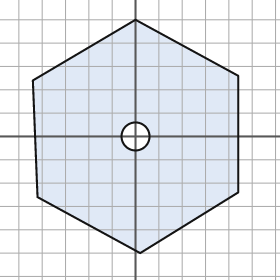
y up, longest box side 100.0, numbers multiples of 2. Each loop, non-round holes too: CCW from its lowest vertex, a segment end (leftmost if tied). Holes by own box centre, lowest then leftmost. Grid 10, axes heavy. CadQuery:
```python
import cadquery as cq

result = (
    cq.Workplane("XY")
    .moveTo(2.0, -50.0)
    .lineTo(44.0, -24.0)
    .lineTo(44.0, 26.0)
    .lineTo(0.0, 50.0)
    .lineTo(-44.0, 24.0)
    .lineTo(-42.0, -26.0)
    .close()
    .moveTo(0.0, 0.0)
    .circle(6.0)
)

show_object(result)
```